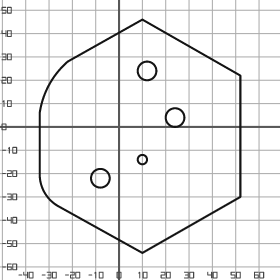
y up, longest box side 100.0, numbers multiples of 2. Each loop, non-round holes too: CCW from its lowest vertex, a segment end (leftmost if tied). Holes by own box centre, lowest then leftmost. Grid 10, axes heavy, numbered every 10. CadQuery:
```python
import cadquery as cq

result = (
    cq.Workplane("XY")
    .moveTo(10.0, -54.0)
    .lineTo(52.0, -30.0)
    .lineTo(52.0, 22.0)
    .lineTo(10.0, 46.0)
    .lineTo(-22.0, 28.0)
    .threePointArc((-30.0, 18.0), (-34.0, 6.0))
    .lineTo(-34.0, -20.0)
    .threePointArc((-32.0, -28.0), (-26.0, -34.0))
    .close()
    .moveTo(-8.0, -22.0)
    .circle(4.0)
    .moveTo(10.0, -14.0)
    .circle(2.0)
    .moveTo(24.0, 4.0)
    .circle(4.0)
    .moveTo(12.0, 24.0)
    .circle(4.0)
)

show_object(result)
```